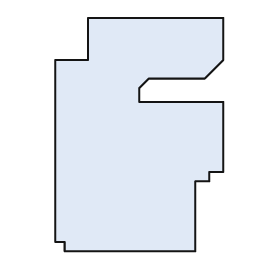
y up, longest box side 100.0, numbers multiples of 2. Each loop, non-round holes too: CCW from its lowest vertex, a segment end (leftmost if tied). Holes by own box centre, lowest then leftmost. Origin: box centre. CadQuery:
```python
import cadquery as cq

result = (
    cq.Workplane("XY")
    .moveTo(-32.0, -50.0)
    .lineTo(24.0, -50.0)
    .lineTo(24.0, -20.0)
    .lineTo(30.0, -20.0)
    .lineTo(30.0, -16.0)
    .lineTo(36.0, -16.0)
    .lineTo(36.0, 14.0)
    .lineTo(0.0, 14.0)
    .lineTo(0.0, 20.0)
    .lineTo(4.0, 24.0)
    .lineTo(28.0, 24.0)
    .lineTo(36.0, 32.0)
    .lineTo(36.0, 50.0)
    .lineTo(-22.0, 50.0)
    .lineTo(-22.0, 32.0)
    .lineTo(-36.0, 32.0)
    .lineTo(-36.0, -46.0)
    .lineTo(-32.0, -46.0)
    .close()
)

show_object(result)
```